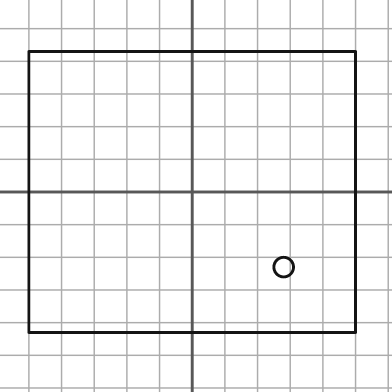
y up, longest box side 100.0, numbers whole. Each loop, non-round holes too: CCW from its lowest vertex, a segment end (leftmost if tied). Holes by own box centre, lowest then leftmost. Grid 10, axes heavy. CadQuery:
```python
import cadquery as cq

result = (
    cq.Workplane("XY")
    .moveTo(-50.0, -43.0)
    .lineTo(50.0, -43.0)
    .lineTo(50.0, 43.0)
    .lineTo(-50.0, 43.0)
    .close()
    .moveTo(28.0, -23.0)
    .circle(3.0)
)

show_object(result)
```